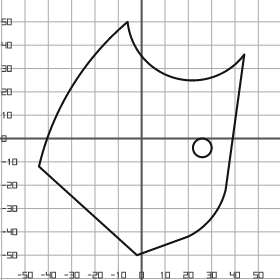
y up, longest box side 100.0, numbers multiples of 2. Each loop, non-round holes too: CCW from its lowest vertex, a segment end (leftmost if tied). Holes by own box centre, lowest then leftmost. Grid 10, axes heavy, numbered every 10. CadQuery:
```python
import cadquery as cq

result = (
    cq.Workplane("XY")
    .moveTo(-2.0, -50.0)
    .lineTo(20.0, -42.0)
    .threePointArc((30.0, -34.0), (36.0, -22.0))
    .lineTo(44.0, 36.0)
    .threePointArc((14.0, 26.0), (-6.0, 50.0))
    .threePointArc((-30.0, 22.0), (-44.0, -12.0))
    .close()
    .moveTo(26.0, -4.0)
    .circle(4.0)
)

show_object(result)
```